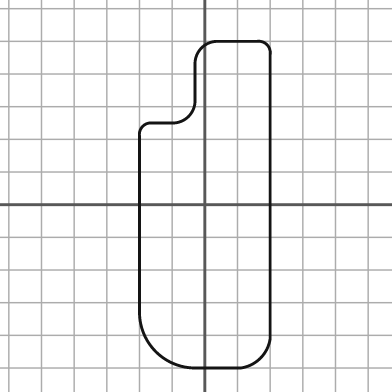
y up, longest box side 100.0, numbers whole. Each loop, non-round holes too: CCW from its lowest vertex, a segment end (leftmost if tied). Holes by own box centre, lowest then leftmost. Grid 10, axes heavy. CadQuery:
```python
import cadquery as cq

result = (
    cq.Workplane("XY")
    .moveTo(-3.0, -50.0)
    .lineTo(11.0, -50.0)
    .threePointArc((17.0, -47.0), (20.0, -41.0))
    .lineTo(20.0, 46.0)
    .threePointArc((19.0, 49.0), (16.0, 50.0))
    .lineTo(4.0, 50.0)
    .threePointArc((-1.0, 48.0), (-3.0, 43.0))
    .lineTo(-3.0, 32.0)
    .threePointArc((-5.0, 27.0), (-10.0, 25.0))
    .lineTo(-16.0, 25.0)
    .threePointArc((-19.0, 24.0), (-20.0, 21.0))
    .lineTo(-20.0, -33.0)
    .threePointArc((-15.0, -45.0), (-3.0, -50.0))
    .close()
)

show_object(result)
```